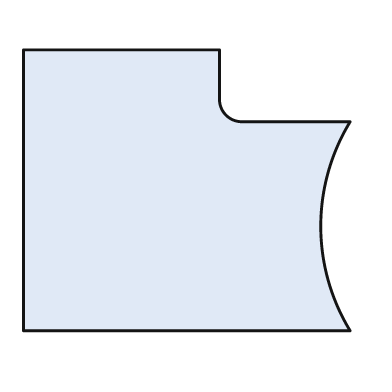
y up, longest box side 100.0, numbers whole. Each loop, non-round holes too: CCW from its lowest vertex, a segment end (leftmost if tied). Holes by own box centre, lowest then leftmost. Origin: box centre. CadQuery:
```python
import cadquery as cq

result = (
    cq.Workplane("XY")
    .moveTo(-50.0, -43.0)
    .lineTo(50.0, -43.0)
    .threePointArc((41.0, -11.0), (50.0, 21.0))
    .lineTo(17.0, 21.0)
    .threePointArc((12.0, 23.0), (10.0, 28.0))
    .lineTo(10.0, 43.0)
    .lineTo(-50.0, 43.0)
    .close()
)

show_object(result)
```